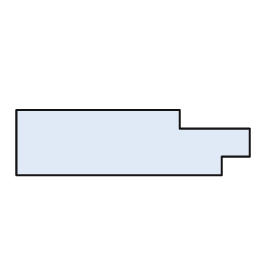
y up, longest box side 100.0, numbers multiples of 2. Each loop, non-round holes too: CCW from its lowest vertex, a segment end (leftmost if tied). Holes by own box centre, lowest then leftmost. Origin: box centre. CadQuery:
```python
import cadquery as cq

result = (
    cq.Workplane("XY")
    .moveTo(-50.0, -14.0)
    .lineTo(38.0, -14.0)
    .lineTo(38.0, -6.0)
    .lineTo(50.0, -6.0)
    .lineTo(50.0, 6.0)
    .lineTo(20.0, 6.0)
    .lineTo(20.0, 14.0)
    .lineTo(-50.0, 14.0)
    .close()
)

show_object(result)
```